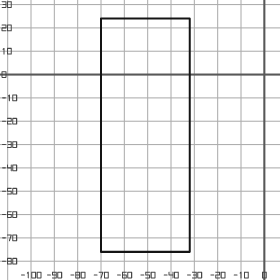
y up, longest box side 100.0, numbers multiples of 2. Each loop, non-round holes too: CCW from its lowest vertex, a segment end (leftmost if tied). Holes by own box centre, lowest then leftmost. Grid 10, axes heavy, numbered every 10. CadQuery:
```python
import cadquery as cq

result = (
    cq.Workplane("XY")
    .moveTo(-70.0, -76.0)
    .lineTo(-32.0, -76.0)
    .lineTo(-32.0, 24.0)
    .lineTo(-70.0, 24.0)
    .close()
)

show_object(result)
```